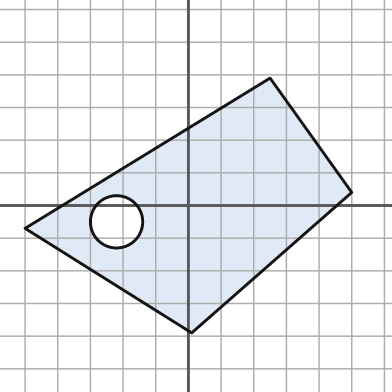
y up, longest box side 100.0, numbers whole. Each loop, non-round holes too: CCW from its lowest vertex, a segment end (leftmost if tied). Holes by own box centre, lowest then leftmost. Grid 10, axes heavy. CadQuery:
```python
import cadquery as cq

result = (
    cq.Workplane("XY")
    .moveTo(1.0, -39.0)
    .lineTo(50.0, 4.0)
    .lineTo(25.0, 39.0)
    .lineTo(-50.0, -7.0)
    .close()
    .moveTo(-22.0, -5.0)
    .circle(8.0)
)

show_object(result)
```